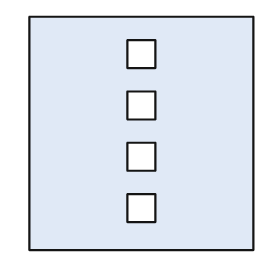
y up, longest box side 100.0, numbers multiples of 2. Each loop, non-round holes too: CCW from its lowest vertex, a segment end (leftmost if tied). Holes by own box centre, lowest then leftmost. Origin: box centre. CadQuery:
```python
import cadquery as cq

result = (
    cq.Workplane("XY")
    .moveTo(-48.0, -50.0)
    .lineTo(48.0, -50.0)
    .lineTo(48.0, 50.0)
    .lineTo(-48.0, 50.0)
    .close()
    .moveTo(-6.0, -38.0)
    .lineTo(6.0, -38.0)
    .lineTo(6.0, -26.0)
    .lineTo(-6.0, -26.0)
    .close()
    .moveTo(-6.0, -16.0)
    .lineTo(6.0, -16.0)
    .lineTo(6.0, -4.0)
    .lineTo(-6.0, -4.0)
    .close()
    .moveTo(-6.0, 6.0)
    .lineTo(6.0, 6.0)
    .lineTo(6.0, 18.0)
    .lineTo(-6.0, 18.0)
    .close()
    .moveTo(-6.0, 28.0)
    .lineTo(6.0, 28.0)
    .lineTo(6.0, 40.0)
    .lineTo(-6.0, 40.0)
    .close()
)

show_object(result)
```